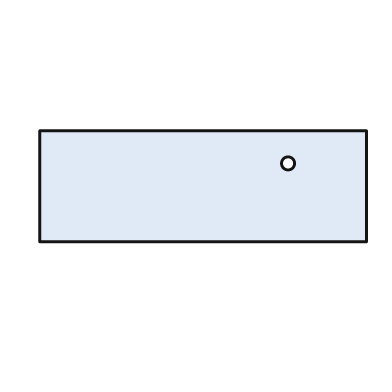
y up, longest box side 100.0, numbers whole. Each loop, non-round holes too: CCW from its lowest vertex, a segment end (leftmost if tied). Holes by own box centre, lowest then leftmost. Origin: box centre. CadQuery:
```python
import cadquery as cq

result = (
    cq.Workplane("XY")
    .moveTo(-50.0, -17.0)
    .lineTo(50.0, -17.0)
    .lineTo(50.0, 17.0)
    .lineTo(-50.0, 17.0)
    .close()
    .moveTo(26.0, 7.0)
    .circle(2.0)
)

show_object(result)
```